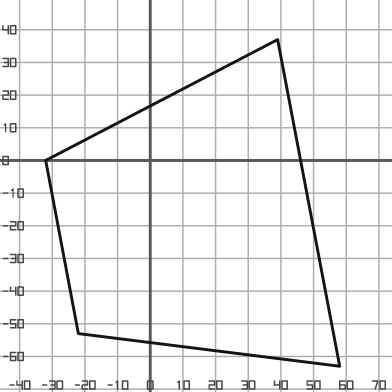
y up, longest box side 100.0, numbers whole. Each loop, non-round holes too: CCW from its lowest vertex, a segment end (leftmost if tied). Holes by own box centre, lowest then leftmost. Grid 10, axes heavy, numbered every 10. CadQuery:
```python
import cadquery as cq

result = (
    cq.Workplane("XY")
    .moveTo(58.0, -63.0)
    .lineTo(39.0, 37.0)
    .lineTo(-32.0, 0.0)
    .lineTo(-22.0, -53.0)
    .close()
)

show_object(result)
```